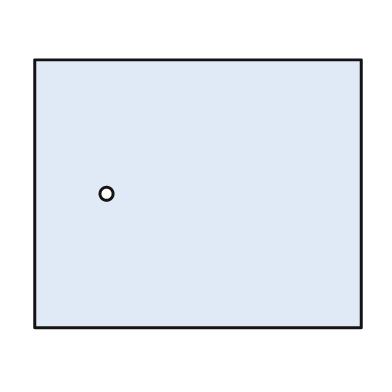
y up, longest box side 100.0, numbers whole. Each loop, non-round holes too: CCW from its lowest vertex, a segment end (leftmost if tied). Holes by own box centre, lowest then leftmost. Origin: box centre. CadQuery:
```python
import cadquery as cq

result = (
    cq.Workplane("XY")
    .moveTo(-50.0, -41.0)
    .lineTo(50.0, -41.0)
    .lineTo(50.0, 41.0)
    .lineTo(-50.0, 41.0)
    .close()
    .moveTo(-28.0, 0.0)
    .circle(2.0)
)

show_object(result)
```